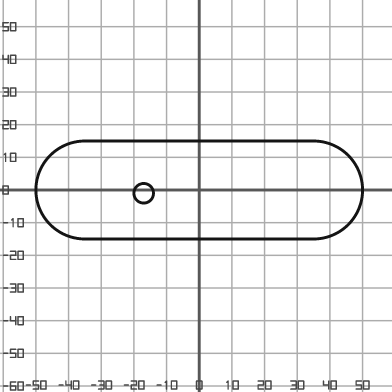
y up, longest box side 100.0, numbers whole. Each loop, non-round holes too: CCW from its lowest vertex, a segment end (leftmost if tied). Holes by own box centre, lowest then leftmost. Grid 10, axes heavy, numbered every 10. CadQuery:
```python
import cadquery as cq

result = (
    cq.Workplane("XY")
    .moveTo(-35.0, -15.0)
    .lineTo(35.0, -15.0)
    .threePointArc((50.0, 0.0), (35.0, 15.0))
    .lineTo(-35.0, 15.0)
    .threePointArc((-50.0, 0.0), (-35.0, -15.0))
    .close()
    .moveTo(-17.0, -1.0)
    .circle(3.0)
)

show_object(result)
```